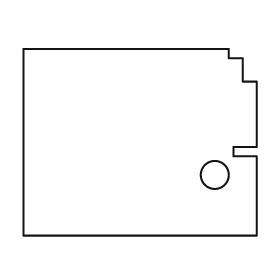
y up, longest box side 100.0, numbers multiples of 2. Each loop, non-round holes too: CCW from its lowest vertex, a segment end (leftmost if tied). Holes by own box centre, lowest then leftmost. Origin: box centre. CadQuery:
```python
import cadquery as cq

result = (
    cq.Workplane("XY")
    .moveTo(-50.0, -40.0)
    .lineTo(50.0, -40.0)
    .lineTo(50.0, -6.0)
    .lineTo(40.0, -6.0)
    .lineTo(40.0, -2.0)
    .lineTo(50.0, -2.0)
    .lineTo(50.0, 26.0)
    .lineTo(44.0, 26.0)
    .lineTo(44.0, 36.0)
    .lineTo(38.0, 36.0)
    .lineTo(38.0, 40.0)
    .lineTo(-50.0, 40.0)
    .close()
    .moveTo(32.0, -14.0)
    .circle(6.0)
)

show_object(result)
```